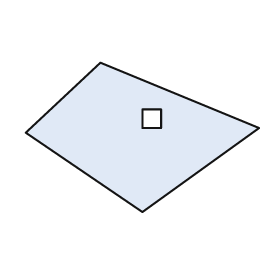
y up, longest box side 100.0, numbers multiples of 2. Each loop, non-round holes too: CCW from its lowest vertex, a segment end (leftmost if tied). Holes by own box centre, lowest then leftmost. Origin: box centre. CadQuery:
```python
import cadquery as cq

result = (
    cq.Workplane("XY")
    .moveTo(0.0, -32.0)
    .lineTo(50.0, 4.0)
    .lineTo(-18.0, 32.0)
    .lineTo(-50.0, 2.0)
    .close()
    .moveTo(0.0, 4.0)
    .lineTo(8.0, 4.0)
    .lineTo(8.0, 12.0)
    .lineTo(0.0, 12.0)
    .close()
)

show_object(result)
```